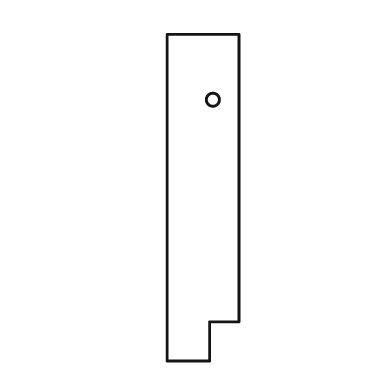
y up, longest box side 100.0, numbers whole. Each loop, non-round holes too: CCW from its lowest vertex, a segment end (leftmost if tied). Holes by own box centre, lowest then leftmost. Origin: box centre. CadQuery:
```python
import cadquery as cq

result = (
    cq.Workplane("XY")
    .moveTo(-11.0, -50.0)
    .lineTo(2.0, -50.0)
    .lineTo(2.0, -38.0)
    .lineTo(11.0, -38.0)
    .lineTo(11.0, 50.0)
    .lineTo(-11.0, 50.0)
    .close()
    .moveTo(3.0, 30.0)
    .circle(2.0)
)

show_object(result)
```